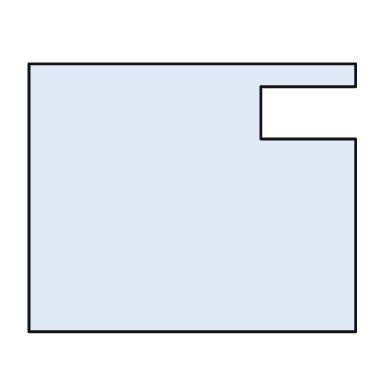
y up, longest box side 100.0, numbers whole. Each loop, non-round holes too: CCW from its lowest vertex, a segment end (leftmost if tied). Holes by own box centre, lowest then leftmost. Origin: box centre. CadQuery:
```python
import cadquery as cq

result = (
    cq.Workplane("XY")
    .moveTo(-50.0, -41.0)
    .lineTo(50.0, -41.0)
    .lineTo(50.0, 18.0)
    .lineTo(21.0, 18.0)
    .lineTo(21.0, 34.0)
    .lineTo(50.0, 34.0)
    .lineTo(50.0, 41.0)
    .lineTo(-50.0, 41.0)
    .close()
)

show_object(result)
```